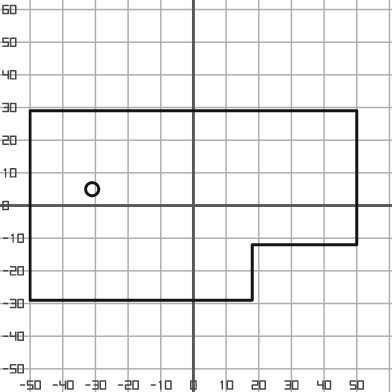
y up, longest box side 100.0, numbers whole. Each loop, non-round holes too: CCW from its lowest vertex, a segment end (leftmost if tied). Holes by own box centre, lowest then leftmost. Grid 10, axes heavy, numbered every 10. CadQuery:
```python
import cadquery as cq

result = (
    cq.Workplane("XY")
    .moveTo(-50.0, -29.0)
    .lineTo(18.0, -29.0)
    .lineTo(18.0, -12.0)
    .lineTo(50.0, -12.0)
    .lineTo(50.0, 29.0)
    .lineTo(-50.0, 29.0)
    .close()
    .moveTo(-31.0, 5.0)
    .circle(2.0)
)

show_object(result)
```